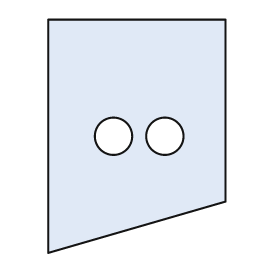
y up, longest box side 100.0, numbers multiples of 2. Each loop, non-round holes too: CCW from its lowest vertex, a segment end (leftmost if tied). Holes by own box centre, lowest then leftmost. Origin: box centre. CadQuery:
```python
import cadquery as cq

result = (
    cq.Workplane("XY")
    .moveTo(-38.0, -50.0)
    .lineTo(38.0, -28.0)
    .lineTo(38.0, 50.0)
    .lineTo(-38.0, 50.0)
    .close()
    .moveTo(-10.0, 0.0)
    .circle(8.0)
    .moveTo(12.0, 0.0)
    .circle(8.0)
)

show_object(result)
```